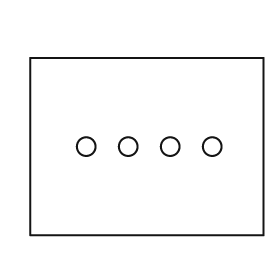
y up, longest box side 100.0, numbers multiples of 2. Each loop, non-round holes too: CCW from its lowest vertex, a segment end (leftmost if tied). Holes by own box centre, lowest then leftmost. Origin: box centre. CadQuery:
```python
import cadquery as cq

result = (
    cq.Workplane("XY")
    .moveTo(-50.0, -38.0)
    .lineTo(50.0, -38.0)
    .lineTo(50.0, 38.0)
    .lineTo(-50.0, 38.0)
    .close()
    .moveTo(-26.0, 0.0)
    .circle(4.0)
    .moveTo(-8.0, 0.0)
    .circle(4.0)
    .moveTo(10.0, 0.0)
    .circle(4.0)
    .moveTo(28.0, 0.0)
    .circle(4.0)
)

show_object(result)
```